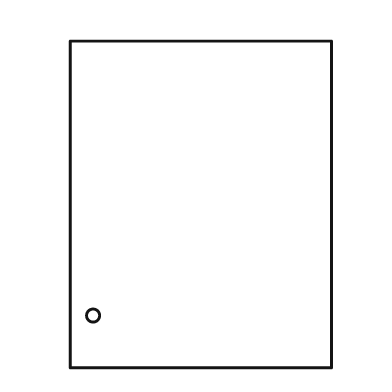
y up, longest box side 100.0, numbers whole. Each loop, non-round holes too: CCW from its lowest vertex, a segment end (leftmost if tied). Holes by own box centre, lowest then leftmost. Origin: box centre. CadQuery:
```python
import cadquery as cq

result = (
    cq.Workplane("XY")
    .moveTo(-40.0, -50.0)
    .lineTo(40.0, -50.0)
    .lineTo(40.0, 50.0)
    .lineTo(-40.0, 50.0)
    .close()
    .moveTo(-33.0, -34.0)
    .circle(2.0)
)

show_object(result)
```